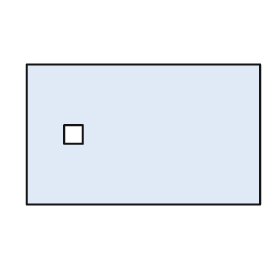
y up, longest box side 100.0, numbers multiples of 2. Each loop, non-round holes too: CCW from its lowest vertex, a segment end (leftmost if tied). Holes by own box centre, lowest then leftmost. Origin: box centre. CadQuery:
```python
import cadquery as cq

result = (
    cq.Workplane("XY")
    .moveTo(-50.0, -30.0)
    .lineTo(50.0, -30.0)
    .lineTo(50.0, 30.0)
    .lineTo(-50.0, 30.0)
    .close()
    .moveTo(-34.0, -4.0)
    .lineTo(-26.0, -4.0)
    .lineTo(-26.0, 4.0)
    .lineTo(-34.0, 4.0)
    .close()
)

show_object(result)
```